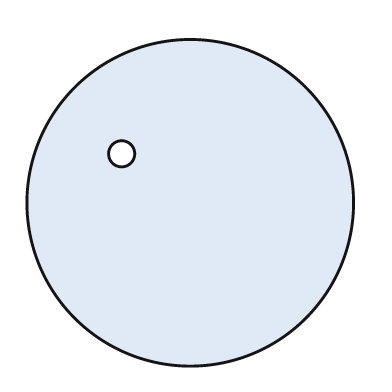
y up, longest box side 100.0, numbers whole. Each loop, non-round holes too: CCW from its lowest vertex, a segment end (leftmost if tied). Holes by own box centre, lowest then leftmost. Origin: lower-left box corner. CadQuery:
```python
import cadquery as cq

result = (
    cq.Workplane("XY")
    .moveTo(50.0, 50.0)
    .circle(50.0)
    .moveTo(29.0, 65.0)
    .circle(4.0)
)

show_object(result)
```